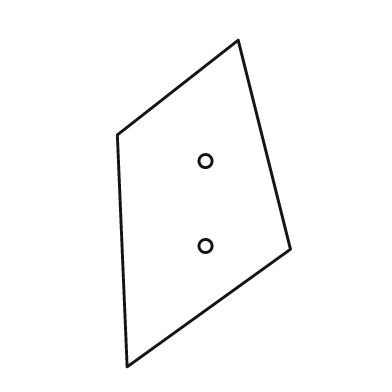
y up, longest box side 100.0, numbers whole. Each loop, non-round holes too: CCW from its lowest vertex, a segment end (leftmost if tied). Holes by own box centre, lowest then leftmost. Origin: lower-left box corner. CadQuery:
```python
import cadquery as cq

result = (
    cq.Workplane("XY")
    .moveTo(3.0, 0.0)
    .lineTo(53.0, 36.0)
    .lineTo(37.0, 100.0)
    .lineTo(0.0, 71.0)
    .close()
    .moveTo(27.0, 37.0)
    .circle(2.0)
    .moveTo(27.0, 63.0)
    .circle(2.0)
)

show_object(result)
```